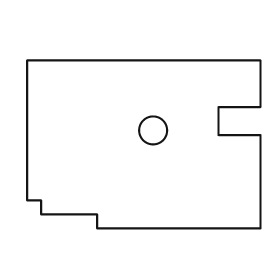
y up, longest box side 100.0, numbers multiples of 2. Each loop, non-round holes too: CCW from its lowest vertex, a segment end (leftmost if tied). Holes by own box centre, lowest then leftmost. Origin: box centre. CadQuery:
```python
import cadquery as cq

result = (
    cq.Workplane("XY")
    .moveTo(-20.0, -36.0)
    .lineTo(50.0, -36.0)
    .lineTo(50.0, 4.0)
    .lineTo(32.0, 4.0)
    .lineTo(32.0, 16.0)
    .lineTo(50.0, 16.0)
    .lineTo(50.0, 36.0)
    .lineTo(-50.0, 36.0)
    .lineTo(-50.0, -24.0)
    .lineTo(-44.0, -24.0)
    .lineTo(-44.0, -30.0)
    .lineTo(-20.0, -30.0)
    .close()
    .moveTo(4.0, 6.0)
    .circle(6.0)
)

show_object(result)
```